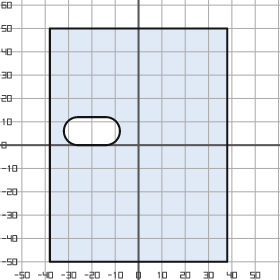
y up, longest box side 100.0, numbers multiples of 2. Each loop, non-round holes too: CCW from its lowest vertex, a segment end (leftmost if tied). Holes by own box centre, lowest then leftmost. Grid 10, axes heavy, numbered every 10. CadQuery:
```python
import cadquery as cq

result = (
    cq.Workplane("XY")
    .moveTo(-38.0, -50.0)
    .lineTo(38.0, -50.0)
    .lineTo(38.0, 50.0)
    .lineTo(-38.0, 50.0)
    .close()
    .moveTo(-26.0, 0.0)
    .lineTo(-14.0, 0.0)
    .threePointArc((-8.0, 6.0), (-14.0, 12.0))
    .lineTo(-26.0, 12.0)
    .threePointArc((-32.0, 6.0), (-26.0, 0.0))
    .close()
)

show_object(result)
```